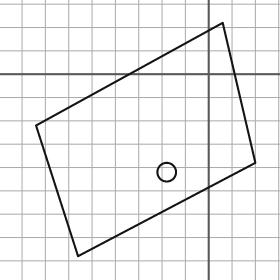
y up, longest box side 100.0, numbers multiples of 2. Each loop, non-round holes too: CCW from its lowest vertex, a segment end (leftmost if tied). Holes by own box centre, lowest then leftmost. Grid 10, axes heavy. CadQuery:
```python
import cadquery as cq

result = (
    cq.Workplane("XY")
    .moveTo(-56.0, -78.0)
    .lineTo(20.0, -38.0)
    .lineTo(6.0, 22.0)
    .lineTo(-74.0, -22.0)
    .close()
    .moveTo(-18.0, -42.0)
    .circle(4.0)
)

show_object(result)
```